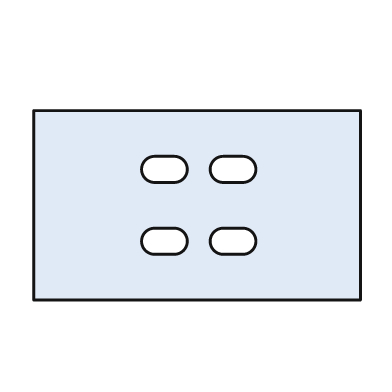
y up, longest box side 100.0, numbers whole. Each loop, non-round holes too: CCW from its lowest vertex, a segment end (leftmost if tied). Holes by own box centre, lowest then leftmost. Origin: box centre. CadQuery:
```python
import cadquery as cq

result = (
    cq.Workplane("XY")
    .moveTo(-50.0, -29.0)
    .lineTo(50.0, -29.0)
    .lineTo(50.0, 29.0)
    .lineTo(-50.0, 29.0)
    .close()
    .moveTo(-13.0, -15.0)
    .lineTo(-7.0, -15.0)
    .threePointArc((-3.0, -11.0), (-7.0, -7.0))
    .lineTo(-13.0, -7.0)
    .threePointArc((-17.0, -11.0), (-13.0, -15.0))
    .close()
    .moveTo(8.0, -15.0)
    .lineTo(14.0, -15.0)
    .threePointArc((18.0, -11.0), (14.0, -7.0))
    .lineTo(8.0, -7.0)
    .threePointArc((4.0, -11.0), (8.0, -15.0))
    .close()
    .moveTo(-13.0, 7.0)
    .lineTo(-7.0, 7.0)
    .threePointArc((-3.0, 11.0), (-7.0, 15.0))
    .lineTo(-13.0, 15.0)
    .threePointArc((-17.0, 11.0), (-13.0, 7.0))
    .close()
    .moveTo(8.0, 7.0)
    .lineTo(14.0, 7.0)
    .threePointArc((18.0, 11.0), (14.0, 15.0))
    .lineTo(8.0, 15.0)
    .threePointArc((4.0, 11.0), (8.0, 7.0))
    .close()
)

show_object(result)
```